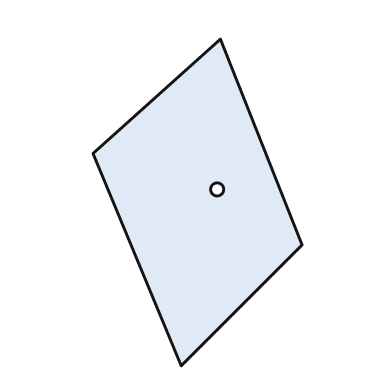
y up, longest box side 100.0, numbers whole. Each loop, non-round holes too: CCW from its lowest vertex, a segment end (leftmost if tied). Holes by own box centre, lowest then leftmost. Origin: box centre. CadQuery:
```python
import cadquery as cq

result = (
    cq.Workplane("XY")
    .moveTo(-5.0, -50.0)
    .lineTo(32.0, -13.0)
    .lineTo(7.0, 50.0)
    .lineTo(-32.0, 15.0)
    .close()
    .moveTo(6.0, 4.0)
    .circle(2.0)
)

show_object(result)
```